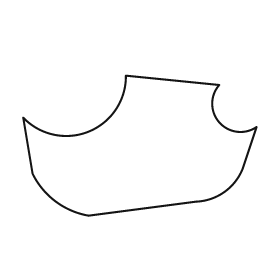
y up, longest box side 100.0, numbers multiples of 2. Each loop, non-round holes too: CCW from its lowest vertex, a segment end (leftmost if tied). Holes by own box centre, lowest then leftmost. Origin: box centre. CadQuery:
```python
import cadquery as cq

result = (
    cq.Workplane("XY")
    .moveTo(-22.0, -30.0)
    .lineTo(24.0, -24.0)
    .threePointArc((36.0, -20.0), (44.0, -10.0))
    .lineTo(50.0, 8.0)
    .threePointArc((34.0, 10.0), (34.0, 26.0))
    .lineTo(-6.0, 30.0)
    .threePointArc((-22.0, 6.0), (-50.0, 12.0))
    .lineTo(-46.0, -12.0)
    .threePointArc((-36.0, -24.0), (-22.0, -30.0))
    .close()
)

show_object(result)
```